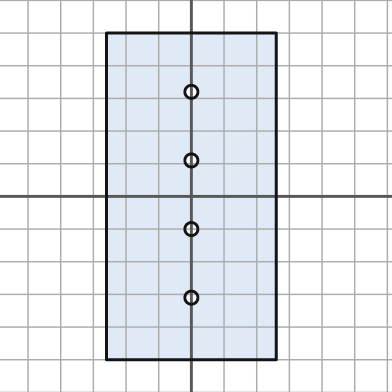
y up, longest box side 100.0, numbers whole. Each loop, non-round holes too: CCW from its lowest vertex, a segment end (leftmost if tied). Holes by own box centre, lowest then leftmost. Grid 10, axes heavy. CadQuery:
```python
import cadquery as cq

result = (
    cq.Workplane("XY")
    .moveTo(-26.0, -50.0)
    .lineTo(26.0, -50.0)
    .lineTo(26.0, 50.0)
    .lineTo(-26.0, 50.0)
    .close()
    .moveTo(0.0, -31.0)
    .circle(2.0)
    .moveTo(0.0, -10.0)
    .circle(2.0)
    .moveTo(0.0, 11.0)
    .circle(2.0)
    .moveTo(0.0, 32.0)
    .circle(2.0)
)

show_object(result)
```